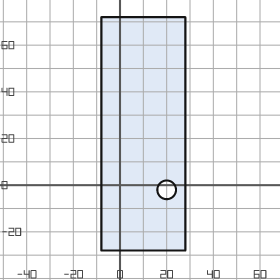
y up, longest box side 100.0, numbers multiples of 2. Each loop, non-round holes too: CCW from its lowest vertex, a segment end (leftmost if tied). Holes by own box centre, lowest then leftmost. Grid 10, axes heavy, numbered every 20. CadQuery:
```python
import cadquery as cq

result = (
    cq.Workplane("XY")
    .moveTo(-8.0, -28.0)
    .lineTo(28.0, -28.0)
    .lineTo(28.0, 72.0)
    .lineTo(-8.0, 72.0)
    .close()
    .moveTo(20.0, -2.0)
    .circle(4.0)
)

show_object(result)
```